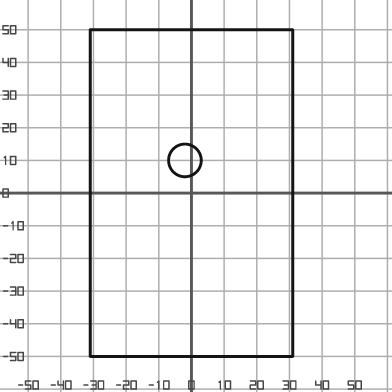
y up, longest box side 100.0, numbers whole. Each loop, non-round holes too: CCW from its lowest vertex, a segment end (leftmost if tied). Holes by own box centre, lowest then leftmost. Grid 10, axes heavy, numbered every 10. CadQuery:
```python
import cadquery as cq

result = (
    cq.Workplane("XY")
    .moveTo(-31.0, -50.0)
    .lineTo(31.0, -50.0)
    .lineTo(31.0, 50.0)
    .lineTo(-31.0, 50.0)
    .close()
    .moveTo(-2.0, 10.0)
    .circle(5.0)
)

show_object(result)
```